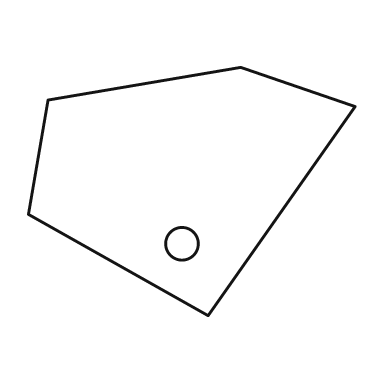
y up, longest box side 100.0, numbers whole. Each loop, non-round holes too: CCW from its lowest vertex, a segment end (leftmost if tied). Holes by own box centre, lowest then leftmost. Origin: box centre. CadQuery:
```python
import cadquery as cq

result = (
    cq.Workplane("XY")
    .moveTo(5.0, -38.0)
    .lineTo(50.0, 26.0)
    .lineTo(15.0, 38.0)
    .lineTo(-44.0, 28.0)
    .lineTo(-50.0, -7.0)
    .close()
    .moveTo(-3.0, -16.0)
    .circle(5.0)
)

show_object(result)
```